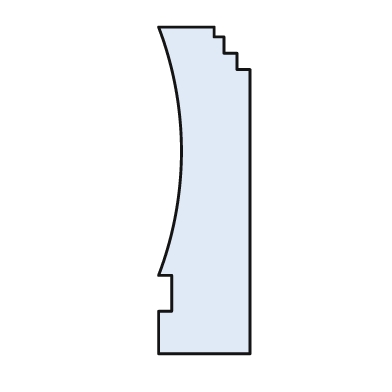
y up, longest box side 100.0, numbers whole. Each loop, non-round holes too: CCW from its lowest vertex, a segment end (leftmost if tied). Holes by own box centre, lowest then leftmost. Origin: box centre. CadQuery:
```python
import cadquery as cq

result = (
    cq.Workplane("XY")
    .moveTo(-14.0, -50.0)
    .lineTo(14.0, -50.0)
    .lineTo(14.0, 37.0)
    .lineTo(10.0, 37.0)
    .lineTo(10.0, 42.0)
    .lineTo(6.0, 42.0)
    .lineTo(6.0, 47.0)
    .lineTo(3.0, 47.0)
    .lineTo(3.0, 50.0)
    .lineTo(-14.0, 50.0)
    .threePointArc((-7.0, 12.0), (-14.0, -26.0))
    .lineTo(-10.0, -26.0)
    .lineTo(-10.0, -37.0)
    .lineTo(-14.0, -37.0)
    .close()
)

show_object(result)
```